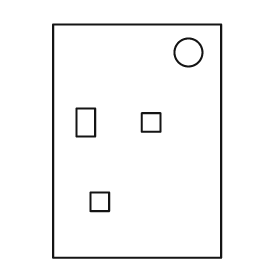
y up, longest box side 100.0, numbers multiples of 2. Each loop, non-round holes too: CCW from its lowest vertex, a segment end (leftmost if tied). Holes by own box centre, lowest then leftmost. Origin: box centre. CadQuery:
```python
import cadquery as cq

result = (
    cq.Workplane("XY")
    .moveTo(-36.0, -50.0)
    .lineTo(36.0, -50.0)
    .lineTo(36.0, 50.0)
    .lineTo(-36.0, 50.0)
    .close()
    .moveTo(-20.0, -30.0)
    .lineTo(-12.0, -30.0)
    .lineTo(-12.0, -22.0)
    .lineTo(-20.0, -22.0)
    .close()
    .moveTo(-26.0, 2.0)
    .lineTo(-18.0, 2.0)
    .lineTo(-18.0, 14.0)
    .lineTo(-26.0, 14.0)
    .close()
    .moveTo(2.0, 4.0)
    .lineTo(10.0, 4.0)
    .lineTo(10.0, 12.0)
    .lineTo(2.0, 12.0)
    .close()
    .moveTo(22.0, 38.0)
    .circle(6.0)
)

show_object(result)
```